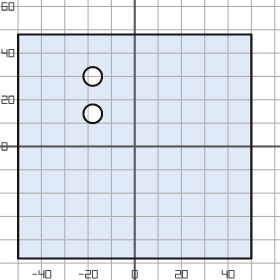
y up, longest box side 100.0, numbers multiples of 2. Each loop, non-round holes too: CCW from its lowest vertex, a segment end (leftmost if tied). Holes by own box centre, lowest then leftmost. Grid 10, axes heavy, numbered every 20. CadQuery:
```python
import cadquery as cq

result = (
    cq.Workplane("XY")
    .moveTo(-50.0, -48.0)
    .lineTo(50.0, -48.0)
    .lineTo(50.0, 48.0)
    .lineTo(-50.0, 48.0)
    .close()
    .moveTo(-18.0, 14.0)
    .circle(4.0)
    .moveTo(-18.0, 30.0)
    .circle(4.0)
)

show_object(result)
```